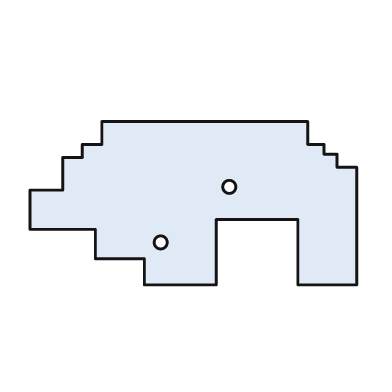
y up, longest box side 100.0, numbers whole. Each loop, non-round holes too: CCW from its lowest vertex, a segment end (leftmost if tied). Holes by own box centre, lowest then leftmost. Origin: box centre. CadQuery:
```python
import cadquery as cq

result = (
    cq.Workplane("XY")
    .moveTo(-15.0, -25.0)
    .lineTo(7.0, -25.0)
    .lineTo(7.0, -5.0)
    .lineTo(32.0, -5.0)
    .lineTo(32.0, -25.0)
    .lineTo(50.0, -25.0)
    .lineTo(50.0, 11.0)
    .lineTo(44.0, 11.0)
    .lineTo(44.0, 15.0)
    .lineTo(40.0, 15.0)
    .lineTo(40.0, 18.0)
    .lineTo(35.0, 18.0)
    .lineTo(35.0, 25.0)
    .lineTo(-28.0, 25.0)
    .lineTo(-28.0, 18.0)
    .lineTo(-34.0, 18.0)
    .lineTo(-34.0, 14.0)
    .lineTo(-40.0, 14.0)
    .lineTo(-40.0, 4.0)
    .lineTo(-50.0, 4.0)
    .lineTo(-50.0, -8.0)
    .lineTo(-30.0, -8.0)
    .lineTo(-30.0, -17.0)
    .lineTo(-15.0, -17.0)
    .close()
    .moveTo(-10.0, -12.0)
    .circle(2.0)
    .moveTo(11.0, 5.0)
    .circle(2.0)
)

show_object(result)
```